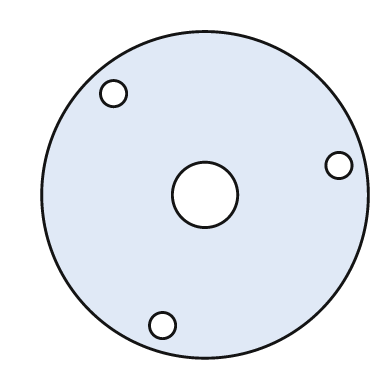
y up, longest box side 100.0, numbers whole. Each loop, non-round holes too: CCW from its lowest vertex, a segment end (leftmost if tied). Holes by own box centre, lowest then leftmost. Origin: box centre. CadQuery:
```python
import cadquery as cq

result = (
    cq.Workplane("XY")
    .moveTo(0.0, 0.0)
    .circle(50.0)
    .moveTo(-13.0, -40.0)
    .circle(4.0)
    .moveTo(0.0, 0.0)
    .circle(10.0)
    .moveTo(41.0, 9.0)
    .circle(4.0)
    .moveTo(-28.0, 31.0)
    .circle(4.0)
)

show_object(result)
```